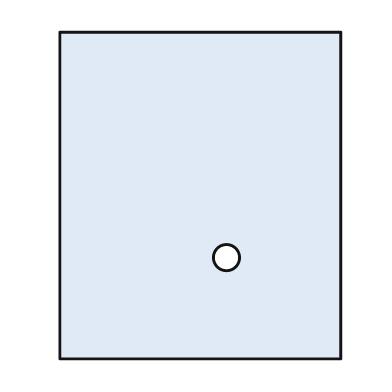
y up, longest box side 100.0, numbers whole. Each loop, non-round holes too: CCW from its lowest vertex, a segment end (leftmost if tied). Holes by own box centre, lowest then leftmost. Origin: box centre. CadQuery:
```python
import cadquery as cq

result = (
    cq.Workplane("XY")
    .moveTo(-43.0, -50.0)
    .lineTo(43.0, -50.0)
    .lineTo(43.0, 50.0)
    .lineTo(-43.0, 50.0)
    .close()
    .moveTo(8.0, -19.0)
    .circle(4.0)
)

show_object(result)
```